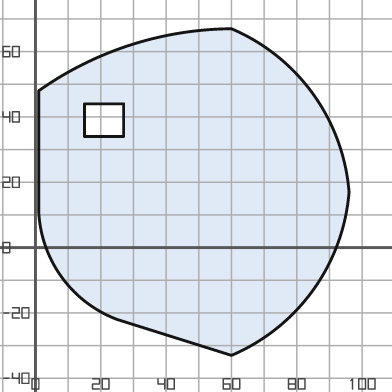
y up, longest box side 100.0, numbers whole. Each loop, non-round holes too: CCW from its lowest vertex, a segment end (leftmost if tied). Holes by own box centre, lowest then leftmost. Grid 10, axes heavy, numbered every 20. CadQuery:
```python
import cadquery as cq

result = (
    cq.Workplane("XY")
    .moveTo(60.0, -33.0)
    .threePointArc((85.0, -13.0), (96.0, 17.0))
    .threePointArc((85.0, 47.0), (60.0, 67.0))
    .threePointArc((29.0, 62.0), (1.0, 48.0))
    .lineTo(1.0, 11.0)
    .threePointArc((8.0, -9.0), (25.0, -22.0))
    .close()
    .moveTo(15.0, 34.0)
    .lineTo(27.0, 34.0)
    .lineTo(27.0, 44.0)
    .lineTo(15.0, 44.0)
    .close()
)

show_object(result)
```